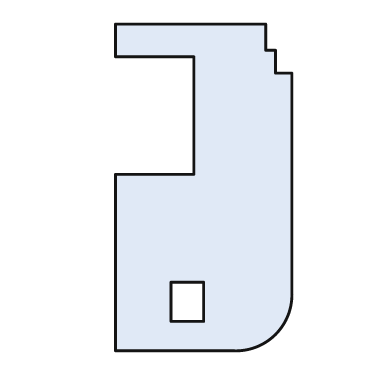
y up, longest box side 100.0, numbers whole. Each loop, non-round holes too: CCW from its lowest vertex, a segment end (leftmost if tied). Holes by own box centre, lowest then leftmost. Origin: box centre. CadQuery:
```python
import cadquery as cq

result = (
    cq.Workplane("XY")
    .moveTo(-27.0, -50.0)
    .lineTo(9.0, -50.0)
    .threePointArc((22.0, -45.0), (27.0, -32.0))
    .lineTo(27.0, 35.0)
    .lineTo(22.0, 35.0)
    .lineTo(22.0, 42.0)
    .lineTo(19.0, 42.0)
    .lineTo(19.0, 50.0)
    .lineTo(-27.0, 50.0)
    .lineTo(-27.0, 40.0)
    .lineTo(-3.0, 40.0)
    .lineTo(-3.0, 4.0)
    .lineTo(-27.0, 4.0)
    .close()
    .moveTo(-10.0, -41.0)
    .lineTo(0.0, -41.0)
    .lineTo(0.0, -29.0)
    .lineTo(-10.0, -29.0)
    .close()
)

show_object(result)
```